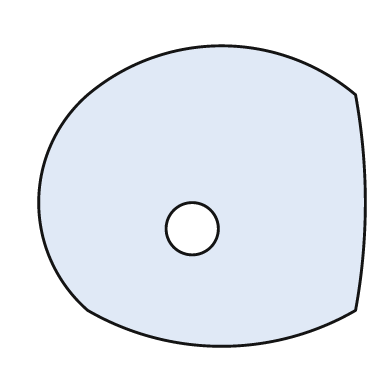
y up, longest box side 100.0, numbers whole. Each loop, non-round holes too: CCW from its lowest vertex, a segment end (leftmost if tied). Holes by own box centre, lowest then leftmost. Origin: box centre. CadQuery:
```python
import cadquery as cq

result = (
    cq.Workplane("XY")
    .moveTo(-35.0, -35.0)
    .threePointArc((6.0, -46.0), (47.0, -35.0))
    .threePointArc((50.0, -2.0), (47.0, 31.0))
    .threePointArc((6.0, 46.0), (-35.0, 31.0))
    .threePointArc((-50.0, -2.0), (-35.0, -35.0))
    .close()
    .moveTo(-3.0, -10.0)
    .circle(8.0)
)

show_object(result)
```